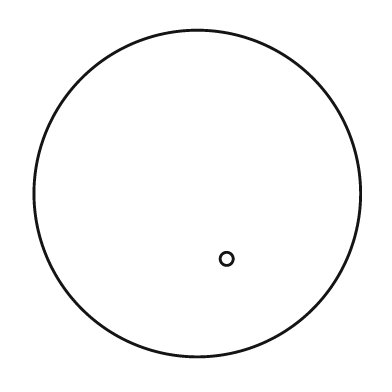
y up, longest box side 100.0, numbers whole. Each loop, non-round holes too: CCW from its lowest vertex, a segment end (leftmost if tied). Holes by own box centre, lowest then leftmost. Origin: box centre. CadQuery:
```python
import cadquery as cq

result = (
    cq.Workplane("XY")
    .moveTo(0.0, 0.0)
    .circle(50.0)
    .moveTo(9.0, -20.0)
    .circle(2.0)
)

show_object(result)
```